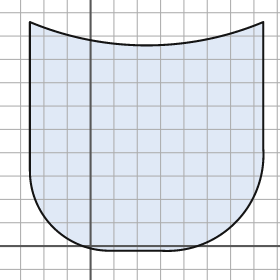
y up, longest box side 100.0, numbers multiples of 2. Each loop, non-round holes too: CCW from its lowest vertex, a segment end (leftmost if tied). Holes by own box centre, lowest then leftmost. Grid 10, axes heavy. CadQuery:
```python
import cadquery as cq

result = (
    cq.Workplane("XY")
    .moveTo(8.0, -2.0)
    .lineTo(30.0, -2.0)
    .threePointArc((62.0, 10.0), (74.0, 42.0))
    .lineTo(74.0, 96.0)
    .threePointArc((24.0, 86.0), (-26.0, 96.0))
    .lineTo(-26.0, 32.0)
    .threePointArc((-16.0, 8.0), (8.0, -2.0))
    .close()
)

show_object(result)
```